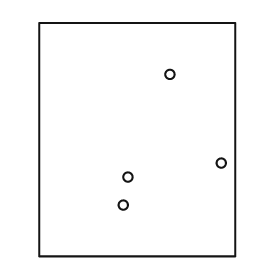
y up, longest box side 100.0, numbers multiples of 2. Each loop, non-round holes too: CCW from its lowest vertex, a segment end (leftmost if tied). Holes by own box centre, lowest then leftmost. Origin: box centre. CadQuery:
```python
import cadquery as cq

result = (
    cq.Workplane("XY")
    .moveTo(-42.0, -50.0)
    .lineTo(42.0, -50.0)
    .lineTo(42.0, 50.0)
    .lineTo(-42.0, 50.0)
    .close()
    .moveTo(-6.0, -28.0)
    .circle(2.0)
    .moveTo(-4.0, -16.0)
    .circle(2.0)
    .moveTo(36.0, -10.0)
    .circle(2.0)
    .moveTo(14.0, 28.0)
    .circle(2.0)
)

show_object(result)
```